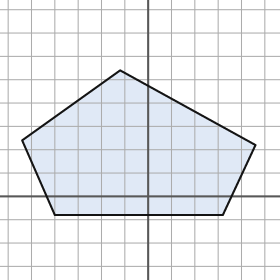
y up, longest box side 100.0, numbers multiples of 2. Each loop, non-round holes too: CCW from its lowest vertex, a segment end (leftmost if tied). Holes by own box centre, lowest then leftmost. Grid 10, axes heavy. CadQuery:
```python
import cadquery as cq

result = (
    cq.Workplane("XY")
    .moveTo(-40.0, -8.0)
    .lineTo(32.0, -8.0)
    .lineTo(46.0, 22.0)
    .lineTo(-12.0, 54.0)
    .lineTo(-54.0, 24.0)
    .close()
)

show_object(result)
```